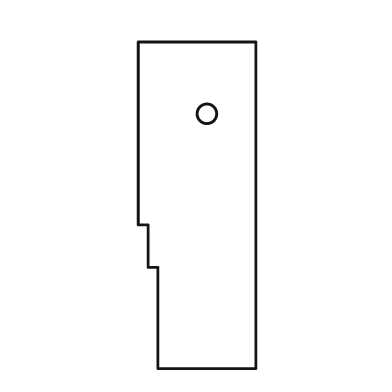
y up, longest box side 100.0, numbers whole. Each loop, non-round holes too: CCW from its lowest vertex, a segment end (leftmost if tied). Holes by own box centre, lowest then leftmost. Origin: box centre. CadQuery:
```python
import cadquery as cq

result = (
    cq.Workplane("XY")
    .moveTo(-12.0, -50.0)
    .lineTo(18.0, -50.0)
    .lineTo(18.0, 50.0)
    .lineTo(-18.0, 50.0)
    .lineTo(-18.0, -6.0)
    .lineTo(-15.0, -6.0)
    .lineTo(-15.0, -19.0)
    .lineTo(-12.0, -19.0)
    .close()
    .moveTo(3.0, 28.0)
    .circle(3.0)
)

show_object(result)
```